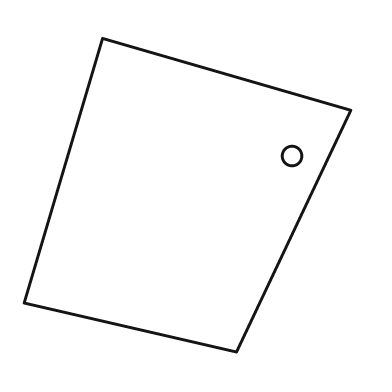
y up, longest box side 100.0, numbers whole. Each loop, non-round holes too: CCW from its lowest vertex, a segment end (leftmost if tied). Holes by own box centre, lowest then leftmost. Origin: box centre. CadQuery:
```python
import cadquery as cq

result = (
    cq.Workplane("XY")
    .moveTo(15.0, -48.0)
    .lineTo(50.0, 26.0)
    .lineTo(-26.0, 48.0)
    .lineTo(-50.0, -33.0)
    .close()
    .moveTo(32.0, 12.0)
    .circle(3.0)
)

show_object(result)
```